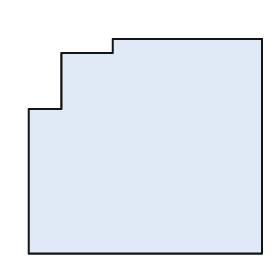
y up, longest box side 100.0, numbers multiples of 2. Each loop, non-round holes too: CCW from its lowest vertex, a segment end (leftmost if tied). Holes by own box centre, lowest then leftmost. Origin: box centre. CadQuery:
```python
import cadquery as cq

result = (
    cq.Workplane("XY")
    .moveTo(-50.0, -46.0)
    .lineTo(50.0, -46.0)
    .lineTo(50.0, 46.0)
    .lineTo(-14.0, 46.0)
    .lineTo(-14.0, 40.0)
    .lineTo(-36.0, 40.0)
    .lineTo(-36.0, 16.0)
    .lineTo(-50.0, 16.0)
    .close()
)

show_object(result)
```